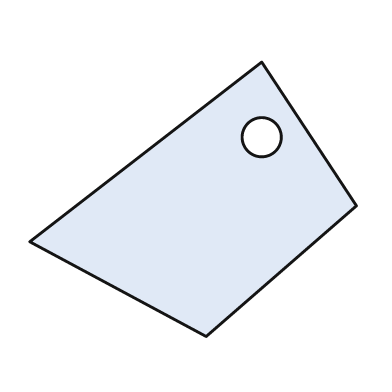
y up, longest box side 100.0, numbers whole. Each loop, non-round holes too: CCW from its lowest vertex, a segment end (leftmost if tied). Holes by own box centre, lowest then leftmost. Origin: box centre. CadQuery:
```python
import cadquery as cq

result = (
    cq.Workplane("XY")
    .moveTo(4.0, -42.0)
    .lineTo(50.0, -2.0)
    .lineTo(21.0, 42.0)
    .lineTo(-50.0, -13.0)
    .close()
    .moveTo(21.0, 19.0)
    .circle(6.0)
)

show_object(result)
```